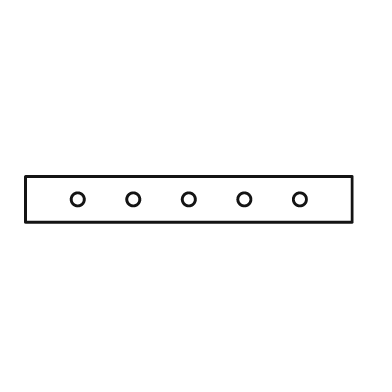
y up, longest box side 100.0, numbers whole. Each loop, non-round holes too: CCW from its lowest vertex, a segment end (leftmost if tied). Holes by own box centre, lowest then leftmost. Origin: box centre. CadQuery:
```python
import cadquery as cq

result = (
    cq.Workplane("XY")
    .moveTo(-50.0, -7.0)
    .lineTo(50.0, -7.0)
    .lineTo(50.0, 7.0)
    .lineTo(-50.0, 7.0)
    .close()
    .moveTo(-34.0, 0.0)
    .circle(2.0)
    .moveTo(-17.0, 0.0)
    .circle(2.0)
    .moveTo(0.0, 0.0)
    .circle(2.0)
    .moveTo(17.0, 0.0)
    .circle(2.0)
    .moveTo(34.0, 0.0)
    .circle(2.0)
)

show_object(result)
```